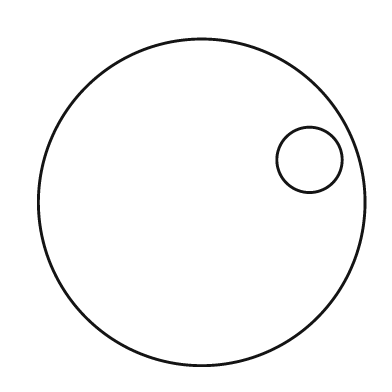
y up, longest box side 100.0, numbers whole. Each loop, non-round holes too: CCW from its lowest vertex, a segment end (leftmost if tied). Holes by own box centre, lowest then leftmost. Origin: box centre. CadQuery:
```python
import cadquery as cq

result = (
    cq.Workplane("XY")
    .moveTo(0.0, 0.0)
    .circle(50.0)
    .moveTo(33.0, 13.0)
    .circle(10.0)
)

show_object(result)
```